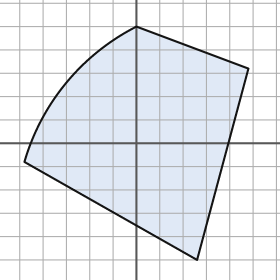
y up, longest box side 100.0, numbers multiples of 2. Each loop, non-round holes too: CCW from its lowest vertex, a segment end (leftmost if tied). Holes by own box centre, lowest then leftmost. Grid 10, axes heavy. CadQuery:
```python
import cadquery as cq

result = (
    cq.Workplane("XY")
    .moveTo(26.0, -50.0)
    .lineTo(48.0, 32.0)
    .lineTo(0.0, 50.0)
    .threePointArc((-30.0, 26.0), (-48.0, -8.0))
    .close()
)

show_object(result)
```